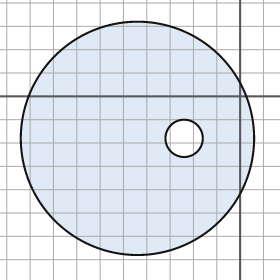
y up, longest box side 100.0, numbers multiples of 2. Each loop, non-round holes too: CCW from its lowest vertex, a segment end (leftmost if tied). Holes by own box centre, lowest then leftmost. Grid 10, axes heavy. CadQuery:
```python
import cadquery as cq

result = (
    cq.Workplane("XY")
    .moveTo(-44.0, -18.0)
    .circle(50.0)
    .moveTo(-24.0, -18.0)
    .circle(8.0)
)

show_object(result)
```